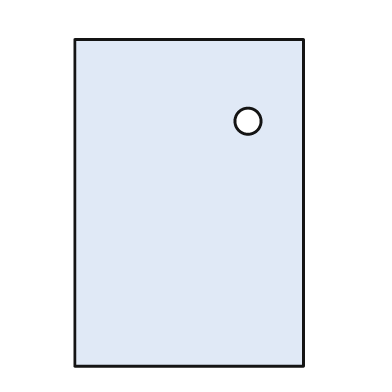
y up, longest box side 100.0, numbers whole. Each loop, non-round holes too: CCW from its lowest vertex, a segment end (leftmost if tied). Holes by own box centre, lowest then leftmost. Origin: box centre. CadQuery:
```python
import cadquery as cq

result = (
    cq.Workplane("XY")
    .moveTo(-35.0, -50.0)
    .lineTo(35.0, -50.0)
    .lineTo(35.0, 50.0)
    .lineTo(-35.0, 50.0)
    .close()
    .moveTo(18.0, 25.0)
    .circle(4.0)
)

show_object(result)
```